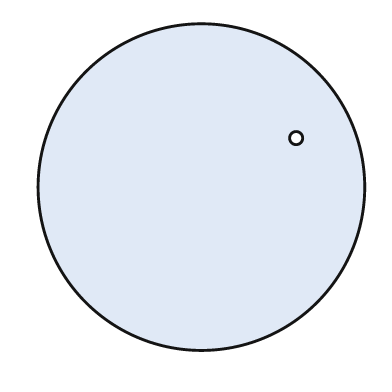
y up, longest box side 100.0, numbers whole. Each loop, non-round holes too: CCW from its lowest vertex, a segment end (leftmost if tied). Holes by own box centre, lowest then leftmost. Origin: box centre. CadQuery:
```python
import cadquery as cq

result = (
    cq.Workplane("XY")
    .moveTo(0.0, 0.0)
    .circle(50.0)
    .moveTo(29.0, 15.0)
    .circle(2.0)
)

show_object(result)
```